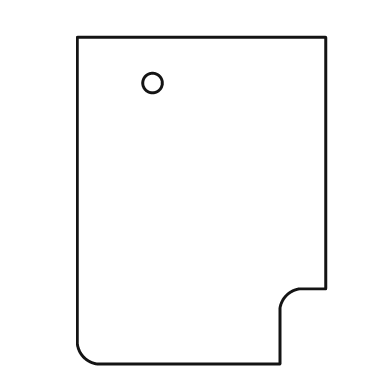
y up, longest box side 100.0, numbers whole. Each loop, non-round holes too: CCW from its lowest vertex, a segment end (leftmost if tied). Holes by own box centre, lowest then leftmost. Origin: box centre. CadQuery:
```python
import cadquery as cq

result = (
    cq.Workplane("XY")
    .moveTo(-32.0, -50.0)
    .lineTo(24.0, -50.0)
    .lineTo(24.0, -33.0)
    .threePointArc((26.0, -29.0), (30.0, -27.0))
    .lineTo(38.0, -27.0)
    .lineTo(38.0, 50.0)
    .lineTo(-38.0, 50.0)
    .lineTo(-38.0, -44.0)
    .threePointArc((-36.0, -48.0), (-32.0, -50.0))
    .close()
    .moveTo(-15.0, 36.0)
    .circle(3.0)
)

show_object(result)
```